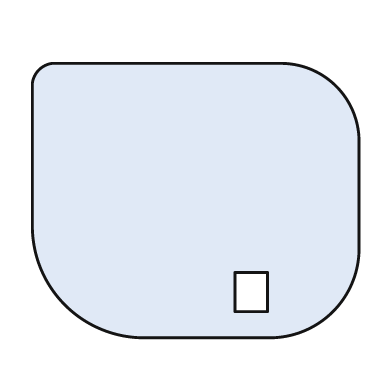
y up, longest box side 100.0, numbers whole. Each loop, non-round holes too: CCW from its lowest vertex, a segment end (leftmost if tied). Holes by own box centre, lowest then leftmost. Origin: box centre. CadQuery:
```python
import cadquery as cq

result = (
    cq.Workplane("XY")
    .moveTo(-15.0, -42.0)
    .lineTo(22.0, -42.0)
    .threePointArc((42.0, -34.0), (50.0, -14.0))
    .lineTo(50.0, 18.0)
    .threePointArc((43.0, 35.0), (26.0, 42.0))
    .lineTo(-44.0, 42.0)
    .threePointArc((-48.0, 40.0), (-50.0, 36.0))
    .lineTo(-50.0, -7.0)
    .threePointArc((-40.0, -32.0), (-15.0, -42.0))
    .close()
    .moveTo(12.0, -34.0)
    .lineTo(22.0, -34.0)
    .lineTo(22.0, -22.0)
    .lineTo(12.0, -22.0)
    .close()
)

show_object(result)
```